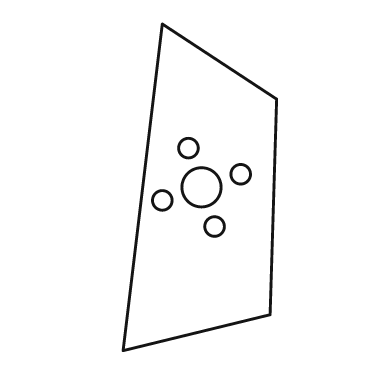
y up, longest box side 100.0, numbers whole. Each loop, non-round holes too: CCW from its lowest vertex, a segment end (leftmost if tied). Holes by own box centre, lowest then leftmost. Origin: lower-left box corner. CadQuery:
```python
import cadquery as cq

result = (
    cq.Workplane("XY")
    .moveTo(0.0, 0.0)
    .lineTo(45.0, 11.0)
    .lineTo(47.0, 77.0)
    .lineTo(12.0, 100.0)
    .close()
    .moveTo(28.0, 38.0)
    .circle(3.0)
    .moveTo(12.0, 46.0)
    .circle(3.0)
    .moveTo(24.0, 50.0)
    .circle(6.0)
    .moveTo(36.0, 54.0)
    .circle(3.0)
    .moveTo(20.0, 62.0)
    .circle(3.0)
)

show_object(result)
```